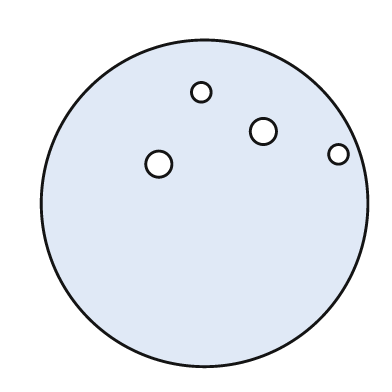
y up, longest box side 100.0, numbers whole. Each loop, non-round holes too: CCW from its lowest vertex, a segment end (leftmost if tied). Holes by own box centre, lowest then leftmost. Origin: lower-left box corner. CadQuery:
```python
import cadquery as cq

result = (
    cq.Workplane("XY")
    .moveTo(50.0, 50.0)
    .circle(50.0)
    .moveTo(36.0, 62.0)
    .circle(4.0)
    .moveTo(91.0, 65.0)
    .circle(3.0)
    .moveTo(68.0, 72.0)
    .circle(4.0)
    .moveTo(49.0, 84.0)
    .circle(3.0)
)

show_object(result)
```